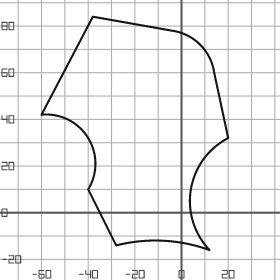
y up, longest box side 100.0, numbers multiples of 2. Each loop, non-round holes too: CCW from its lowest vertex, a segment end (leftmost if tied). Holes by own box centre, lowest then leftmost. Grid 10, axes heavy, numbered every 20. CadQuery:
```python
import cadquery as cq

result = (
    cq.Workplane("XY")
    .moveTo(12.0, -16.0)
    .threePointArc((4.0, 10.0), (20.0, 32.0))
    .lineTo(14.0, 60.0)
    .threePointArc((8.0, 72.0), (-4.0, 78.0))
    .lineTo(-38.0, 84.0)
    .lineTo(-60.0, 42.0)
    .threePointArc((-40.0, 32.0), (-40.0, 10.0))
    .lineTo(-28.0, -14.0)
    .threePointArc((-8.0, -12.0), (12.0, -16.0))
    .close()
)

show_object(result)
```